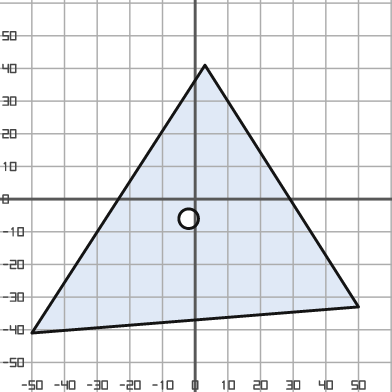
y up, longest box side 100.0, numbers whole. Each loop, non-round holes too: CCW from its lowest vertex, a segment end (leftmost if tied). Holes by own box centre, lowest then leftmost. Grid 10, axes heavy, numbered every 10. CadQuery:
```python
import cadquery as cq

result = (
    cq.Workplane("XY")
    .moveTo(-50.0, -41.0)
    .lineTo(50.0, -33.0)
    .lineTo(3.0, 41.0)
    .close()
    .moveTo(-2.0, -6.0)
    .circle(3.0)
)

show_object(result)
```